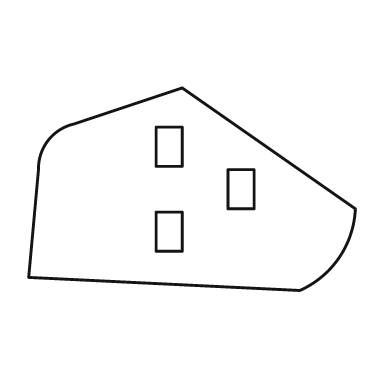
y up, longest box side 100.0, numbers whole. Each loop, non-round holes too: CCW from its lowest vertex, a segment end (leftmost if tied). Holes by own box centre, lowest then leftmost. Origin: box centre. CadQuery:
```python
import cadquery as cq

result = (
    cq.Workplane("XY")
    .moveTo(33.0, -31.0)
    .threePointArc((45.0, -21.0), (50.0, -6.0))
    .lineTo(-3.0, 31.0)
    .lineTo(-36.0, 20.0)
    .threePointArc((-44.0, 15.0), (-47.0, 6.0))
    .lineTo(-50.0, -27.0)
    .close()
    .moveTo(-11.0, -19.0)
    .lineTo(-3.0, -19.0)
    .lineTo(-3.0, -7.0)
    .lineTo(-11.0, -7.0)
    .close()
    .moveTo(11.0, -6.0)
    .lineTo(19.0, -6.0)
    .lineTo(19.0, 6.0)
    .lineTo(11.0, 6.0)
    .close()
    .moveTo(-11.0, 7.0)
    .lineTo(-3.0, 7.0)
    .lineTo(-3.0, 19.0)
    .lineTo(-11.0, 19.0)
    .close()
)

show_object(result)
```